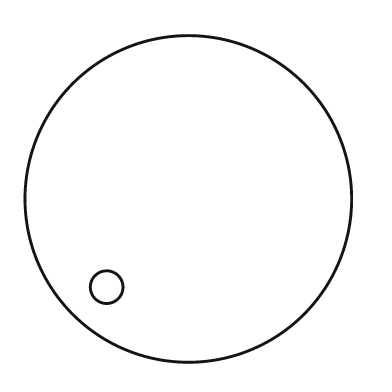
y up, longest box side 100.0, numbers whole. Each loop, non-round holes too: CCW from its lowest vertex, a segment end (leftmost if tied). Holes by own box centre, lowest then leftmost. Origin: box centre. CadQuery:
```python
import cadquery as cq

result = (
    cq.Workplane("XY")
    .moveTo(0.0, 0.0)
    .circle(50.0)
    .moveTo(-25.0, -27.0)
    .circle(5.0)
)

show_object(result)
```